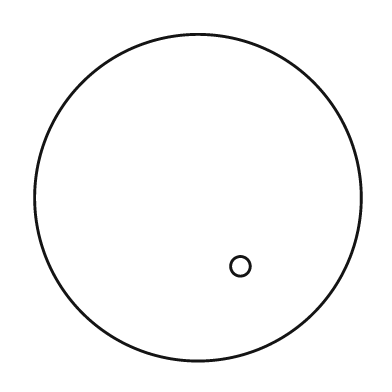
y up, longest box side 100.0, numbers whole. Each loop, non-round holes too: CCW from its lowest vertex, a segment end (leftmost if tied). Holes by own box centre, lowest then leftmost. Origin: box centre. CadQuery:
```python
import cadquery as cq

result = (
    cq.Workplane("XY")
    .moveTo(0.0, 0.0)
    .circle(50.0)
    .moveTo(13.0, -21.0)
    .circle(3.0)
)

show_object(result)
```